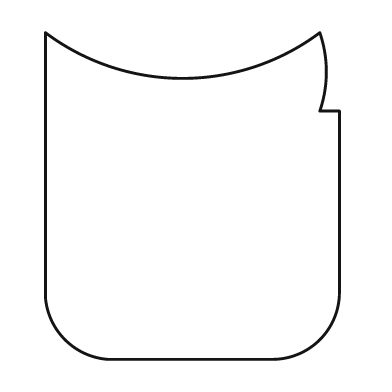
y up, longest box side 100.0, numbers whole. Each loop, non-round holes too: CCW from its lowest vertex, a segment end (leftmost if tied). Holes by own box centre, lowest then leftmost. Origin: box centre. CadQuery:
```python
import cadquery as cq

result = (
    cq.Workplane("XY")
    .moveTo(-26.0, -50.0)
    .lineTo(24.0, -50.0)
    .threePointArc((39.0, -44.0), (45.0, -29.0))
    .lineTo(45.0, 26.0)
    .lineTo(39.0, 26.0)
    .threePointArc((41.0, 38.0), (39.0, 50.0))
    .threePointArc((-3.0, 36.0), (-45.0, 50.0))
    .lineTo(-45.0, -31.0)
    .threePointArc((-39.0, -44.0), (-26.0, -50.0))
    .close()
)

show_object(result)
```